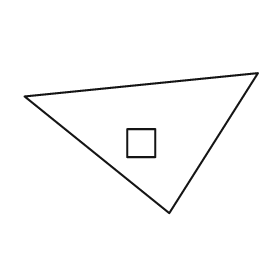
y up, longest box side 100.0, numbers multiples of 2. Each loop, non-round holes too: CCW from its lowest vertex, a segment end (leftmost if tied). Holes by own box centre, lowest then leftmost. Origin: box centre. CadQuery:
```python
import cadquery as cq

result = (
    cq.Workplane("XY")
    .moveTo(12.0, -30.0)
    .lineTo(50.0, 30.0)
    .lineTo(-50.0, 20.0)
    .close()
    .moveTo(-6.0, -6.0)
    .lineTo(6.0, -6.0)
    .lineTo(6.0, 6.0)
    .lineTo(-6.0, 6.0)
    .close()
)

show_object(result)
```